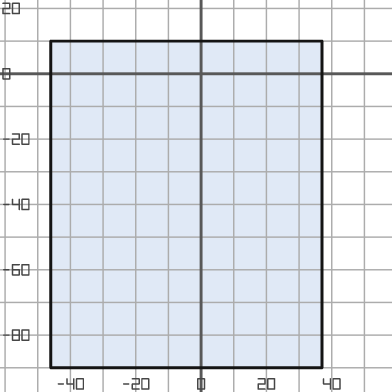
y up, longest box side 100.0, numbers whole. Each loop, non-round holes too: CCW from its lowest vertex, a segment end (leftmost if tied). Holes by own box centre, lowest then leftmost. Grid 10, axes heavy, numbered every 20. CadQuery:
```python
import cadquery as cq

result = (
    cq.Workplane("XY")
    .moveTo(-46.0, -90.0)
    .lineTo(37.0, -90.0)
    .lineTo(37.0, 10.0)
    .lineTo(-46.0, 10.0)
    .close()
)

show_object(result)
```